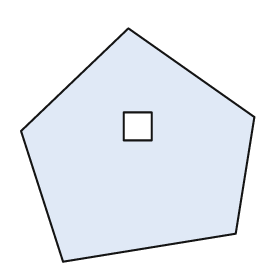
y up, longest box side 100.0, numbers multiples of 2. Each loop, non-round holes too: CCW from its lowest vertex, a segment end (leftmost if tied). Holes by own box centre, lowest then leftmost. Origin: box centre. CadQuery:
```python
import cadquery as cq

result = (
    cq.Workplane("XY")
    .moveTo(-32.0, -50.0)
    .lineTo(42.0, -38.0)
    .lineTo(50.0, 12.0)
    .lineTo(-4.0, 50.0)
    .lineTo(-50.0, 6.0)
    .close()
    .moveTo(-6.0, 2.0)
    .lineTo(6.0, 2.0)
    .lineTo(6.0, 14.0)
    .lineTo(-6.0, 14.0)
    .close()
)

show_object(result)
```